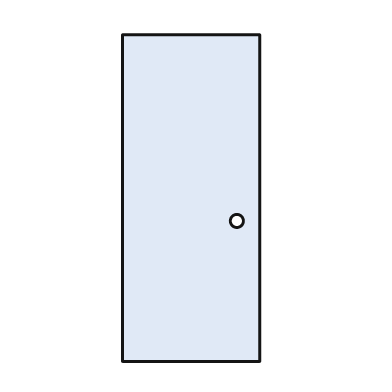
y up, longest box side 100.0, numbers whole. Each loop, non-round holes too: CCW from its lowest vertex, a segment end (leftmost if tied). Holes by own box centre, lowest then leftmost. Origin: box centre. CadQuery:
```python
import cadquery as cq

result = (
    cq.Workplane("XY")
    .moveTo(-21.0, -50.0)
    .lineTo(21.0, -50.0)
    .lineTo(21.0, 50.0)
    .lineTo(-21.0, 50.0)
    .close()
    .moveTo(14.0, -7.0)
    .circle(2.0)
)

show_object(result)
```